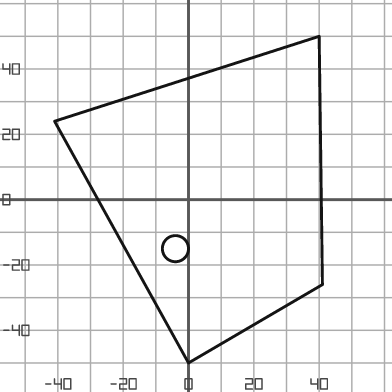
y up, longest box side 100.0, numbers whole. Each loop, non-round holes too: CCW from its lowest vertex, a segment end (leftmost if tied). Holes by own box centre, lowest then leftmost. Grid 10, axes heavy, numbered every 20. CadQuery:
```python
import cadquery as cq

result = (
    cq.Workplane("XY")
    .moveTo(0.0, -50.0)
    .lineTo(41.0, -26.0)
    .lineTo(40.0, 50.0)
    .lineTo(-41.0, 24.0)
    .close()
    .moveTo(-4.0, -15.0)
    .circle(4.0)
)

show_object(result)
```